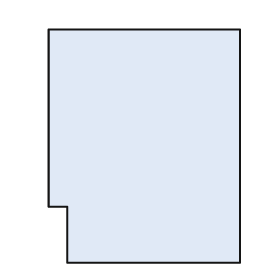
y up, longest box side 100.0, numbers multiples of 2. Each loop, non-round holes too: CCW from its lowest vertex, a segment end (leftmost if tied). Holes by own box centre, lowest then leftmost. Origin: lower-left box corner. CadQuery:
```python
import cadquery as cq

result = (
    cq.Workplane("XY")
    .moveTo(8.0, 0.0)
    .lineTo(82.0, 0.0)
    .lineTo(82.0, 100.0)
    .lineTo(0.0, 100.0)
    .lineTo(0.0, 24.0)
    .lineTo(8.0, 24.0)
    .close()
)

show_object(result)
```